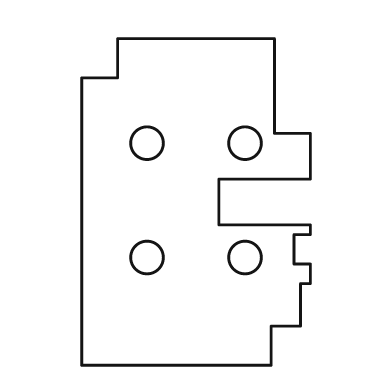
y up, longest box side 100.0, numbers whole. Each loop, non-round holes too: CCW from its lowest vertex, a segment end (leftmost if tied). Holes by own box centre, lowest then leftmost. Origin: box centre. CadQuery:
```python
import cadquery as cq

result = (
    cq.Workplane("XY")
    .moveTo(-35.0, -50.0)
    .lineTo(23.0, -50.0)
    .lineTo(23.0, -38.0)
    .lineTo(32.0, -38.0)
    .lineTo(32.0, -25.0)
    .lineTo(35.0, -25.0)
    .lineTo(35.0, -19.0)
    .lineTo(30.0, -19.0)
    .lineTo(30.0, -10.0)
    .lineTo(35.0, -10.0)
    .lineTo(35.0, -7.0)
    .lineTo(7.0, -7.0)
    .lineTo(7.0, 7.0)
    .lineTo(35.0, 7.0)
    .lineTo(35.0, 21.0)
    .lineTo(24.0, 21.0)
    .lineTo(24.0, 50.0)
    .lineTo(-24.0, 50.0)
    .lineTo(-24.0, 38.0)
    .lineTo(-35.0, 38.0)
    .close()
    .moveTo(-15.0, -17.0)
    .circle(5.0)
    .moveTo(15.0, -17.0)
    .circle(5.0)
    .moveTo(-15.0, 18.0)
    .circle(5.0)
    .moveTo(15.0, 18.0)
    .circle(5.0)
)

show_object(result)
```